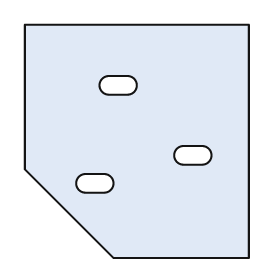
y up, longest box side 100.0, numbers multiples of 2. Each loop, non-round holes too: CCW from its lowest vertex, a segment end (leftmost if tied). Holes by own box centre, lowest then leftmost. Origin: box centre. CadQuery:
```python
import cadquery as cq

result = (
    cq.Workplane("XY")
    .moveTo(-10.0, -50.0)
    .lineTo(48.0, -50.0)
    .lineTo(48.0, 50.0)
    .lineTo(-48.0, 50.0)
    .lineTo(-48.0, -12.0)
    .close()
    .moveTo(-22.0, -22.0)
    .lineTo(-14.0, -22.0)
    .threePointArc((-10.0, -18.0), (-14.0, -14.0))
    .lineTo(-22.0, -14.0)
    .threePointArc((-26.0, -18.0), (-22.0, -22.0))
    .close()
    .moveTo(20.0, -10.0)
    .lineTo(28.0, -10.0)
    .threePointArc((32.0, -6.0), (28.0, -2.0))
    .lineTo(20.0, -2.0)
    .threePointArc((16.0, -6.0), (20.0, -10.0))
    .close()
    .moveTo(-12.0, 20.0)
    .lineTo(-4.0, 20.0)
    .threePointArc((0.0, 24.0), (-4.0, 28.0))
    .lineTo(-12.0, 28.0)
    .threePointArc((-16.0, 24.0), (-12.0, 20.0))
    .close()
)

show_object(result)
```